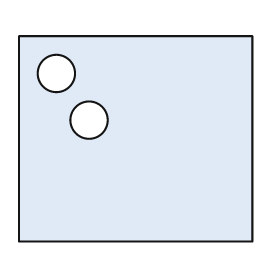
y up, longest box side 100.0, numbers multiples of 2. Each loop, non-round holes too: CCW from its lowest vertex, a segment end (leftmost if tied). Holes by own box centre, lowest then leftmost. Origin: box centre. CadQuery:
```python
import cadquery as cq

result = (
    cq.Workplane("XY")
    .moveTo(-50.0, -44.0)
    .lineTo(50.0, -44.0)
    .lineTo(50.0, 44.0)
    .lineTo(-50.0, 44.0)
    .close()
    .moveTo(-20.0, 8.0)
    .circle(8.0)
    .moveTo(-34.0, 28.0)
    .circle(8.0)
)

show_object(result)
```